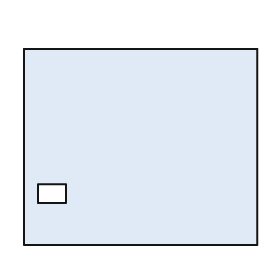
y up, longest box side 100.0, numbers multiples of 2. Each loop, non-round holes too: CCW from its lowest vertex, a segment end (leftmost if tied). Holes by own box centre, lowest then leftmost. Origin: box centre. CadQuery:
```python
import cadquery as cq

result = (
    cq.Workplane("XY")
    .moveTo(-50.0, -42.0)
    .lineTo(50.0, -42.0)
    .lineTo(50.0, 42.0)
    .lineTo(-50.0, 42.0)
    .close()
    .moveTo(-44.0, -24.0)
    .lineTo(-32.0, -24.0)
    .lineTo(-32.0, -16.0)
    .lineTo(-44.0, -16.0)
    .close()
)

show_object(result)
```